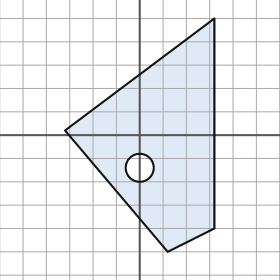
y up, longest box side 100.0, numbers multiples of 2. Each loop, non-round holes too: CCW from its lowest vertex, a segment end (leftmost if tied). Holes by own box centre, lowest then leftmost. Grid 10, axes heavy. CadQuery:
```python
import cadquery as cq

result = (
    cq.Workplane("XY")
    .moveTo(12.0, -50.0)
    .lineTo(32.0, -40.0)
    .lineTo(32.0, 50.0)
    .lineTo(-32.0, 2.0)
    .close()
    .moveTo(0.0, -14.0)
    .circle(6.0)
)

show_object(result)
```